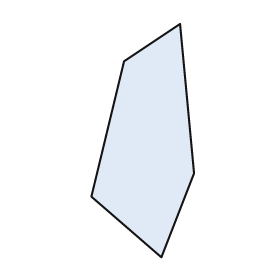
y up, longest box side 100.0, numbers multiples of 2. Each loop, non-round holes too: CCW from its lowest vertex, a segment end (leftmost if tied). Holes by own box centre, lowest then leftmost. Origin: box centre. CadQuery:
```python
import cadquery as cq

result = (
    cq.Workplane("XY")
    .moveTo(8.0, -50.0)
    .lineTo(22.0, -14.0)
    .lineTo(16.0, 50.0)
    .lineTo(-8.0, 34.0)
    .lineTo(-22.0, -24.0)
    .close()
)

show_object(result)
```